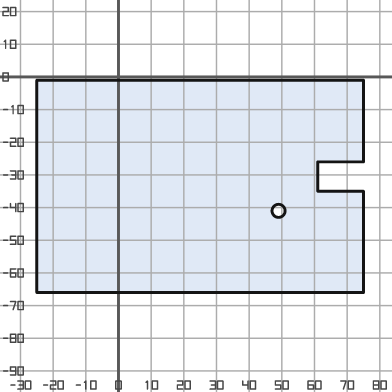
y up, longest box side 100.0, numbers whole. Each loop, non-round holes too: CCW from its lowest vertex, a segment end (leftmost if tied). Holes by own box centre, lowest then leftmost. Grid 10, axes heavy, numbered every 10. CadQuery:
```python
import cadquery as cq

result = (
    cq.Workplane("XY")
    .moveTo(-25.0, -66.0)
    .lineTo(75.0, -66.0)
    .lineTo(75.0, -35.0)
    .lineTo(61.0, -35.0)
    .lineTo(61.0, -26.0)
    .lineTo(75.0, -26.0)
    .lineTo(75.0, -1.0)
    .lineTo(-25.0, -1.0)
    .close()
    .moveTo(49.0, -41.0)
    .circle(2.0)
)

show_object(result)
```